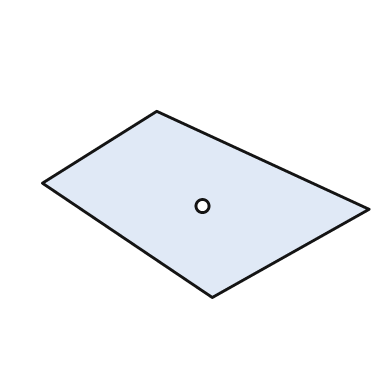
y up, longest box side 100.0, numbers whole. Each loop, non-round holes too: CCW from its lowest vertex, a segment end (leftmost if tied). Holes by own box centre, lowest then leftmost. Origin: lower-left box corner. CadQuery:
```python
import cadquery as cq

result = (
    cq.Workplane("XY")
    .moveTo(52.0, 0.0)
    .lineTo(100.0, 27.0)
    .lineTo(35.0, 57.0)
    .lineTo(0.0, 35.0)
    .close()
    .moveTo(49.0, 28.0)
    .circle(2.0)
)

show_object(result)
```